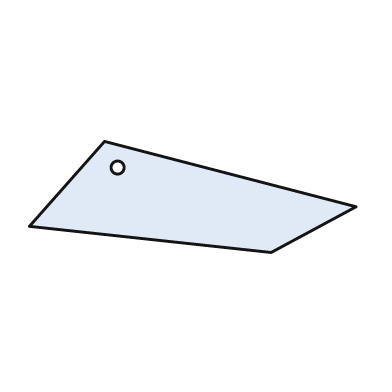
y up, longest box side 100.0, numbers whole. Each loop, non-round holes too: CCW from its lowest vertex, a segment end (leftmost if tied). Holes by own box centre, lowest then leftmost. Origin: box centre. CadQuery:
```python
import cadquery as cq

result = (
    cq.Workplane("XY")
    .moveTo(24.0, -17.0)
    .lineTo(50.0, -3.0)
    .lineTo(-27.0, 17.0)
    .lineTo(-50.0, -9.0)
    .close()
    .moveTo(-23.0, 9.0)
    .circle(2.0)
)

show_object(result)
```